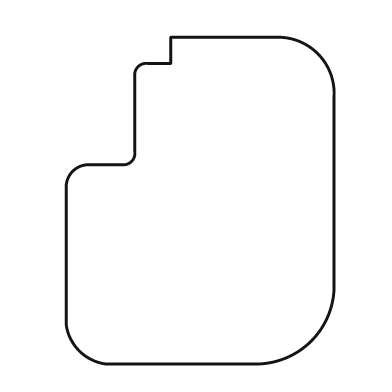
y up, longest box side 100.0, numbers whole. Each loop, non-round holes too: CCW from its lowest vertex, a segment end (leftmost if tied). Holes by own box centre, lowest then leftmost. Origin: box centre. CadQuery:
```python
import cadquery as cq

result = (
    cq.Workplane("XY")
    .moveTo(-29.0, -50.0)
    .lineTo(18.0, -50.0)
    .threePointArc((34.0, -43.0), (41.0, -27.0))
    .lineTo(41.0, 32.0)
    .threePointArc((36.0, 45.0), (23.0, 50.0))
    .lineTo(-9.0, 50.0)
    .lineTo(-9.0, 42.0)
    .lineTo(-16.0, 42.0)
    .threePointArc((-19.0, 41.0), (-20.0, 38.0))
    .lineTo(-20.0, 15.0)
    .threePointArc((-21.0, 12.0), (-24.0, 11.0))
    .lineTo(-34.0, 11.0)
    .threePointArc((-39.0, 9.0), (-41.0, 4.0))
    .lineTo(-41.0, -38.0)
    .threePointArc((-37.0, -46.0), (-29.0, -50.0))
    .close()
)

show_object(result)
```